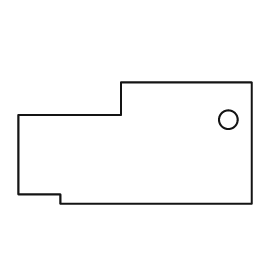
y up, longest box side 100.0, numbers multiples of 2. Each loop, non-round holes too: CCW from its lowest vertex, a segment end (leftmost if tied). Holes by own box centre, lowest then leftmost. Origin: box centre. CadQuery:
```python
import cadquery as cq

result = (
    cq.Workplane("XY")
    .moveTo(-32.0, -26.0)
    .lineTo(50.0, -26.0)
    .lineTo(50.0, 26.0)
    .lineTo(-6.0, 26.0)
    .lineTo(-6.0, 12.0)
    .lineTo(-50.0, 12.0)
    .lineTo(-50.0, -22.0)
    .lineTo(-32.0, -22.0)
    .close()
    .moveTo(40.0, 10.0)
    .circle(4.0)
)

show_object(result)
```